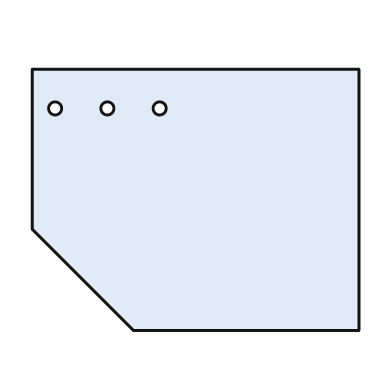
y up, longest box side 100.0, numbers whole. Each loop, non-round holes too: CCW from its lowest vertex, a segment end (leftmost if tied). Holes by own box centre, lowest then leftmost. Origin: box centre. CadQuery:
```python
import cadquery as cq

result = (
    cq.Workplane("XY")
    .moveTo(-19.0, -40.0)
    .lineTo(50.0, -40.0)
    .lineTo(50.0, 40.0)
    .lineTo(-50.0, 40.0)
    .lineTo(-50.0, -9.0)
    .close()
    .moveTo(-43.0, 28.0)
    .circle(2.0)
    .moveTo(-27.0, 28.0)
    .circle(2.0)
    .moveTo(-11.0, 28.0)
    .circle(2.0)
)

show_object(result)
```